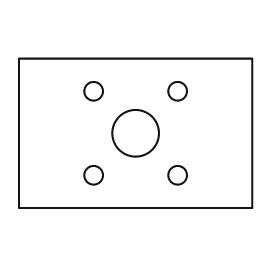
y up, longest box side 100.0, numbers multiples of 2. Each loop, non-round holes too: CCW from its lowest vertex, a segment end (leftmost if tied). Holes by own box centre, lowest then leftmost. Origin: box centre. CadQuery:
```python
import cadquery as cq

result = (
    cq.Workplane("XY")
    .moveTo(-50.0, -32.0)
    .lineTo(50.0, -32.0)
    .lineTo(50.0, 32.0)
    .lineTo(-50.0, 32.0)
    .close()
    .moveTo(-18.0, -18.0)
    .circle(4.0)
    .moveTo(18.0, -18.0)
    .circle(4.0)
    .moveTo(0.0, 0.0)
    .circle(10.0)
    .moveTo(-18.0, 18.0)
    .circle(4.0)
    .moveTo(18.0, 18.0)
    .circle(4.0)
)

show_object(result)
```